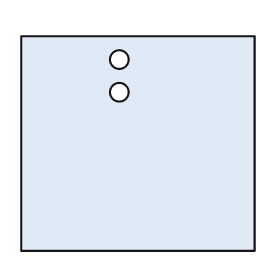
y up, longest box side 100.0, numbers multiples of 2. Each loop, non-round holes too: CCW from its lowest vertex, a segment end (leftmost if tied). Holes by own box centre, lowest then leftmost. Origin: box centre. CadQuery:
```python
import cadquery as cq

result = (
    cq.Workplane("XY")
    .moveTo(-50.0, -46.0)
    .lineTo(50.0, -46.0)
    .lineTo(50.0, 46.0)
    .lineTo(-50.0, 46.0)
    .close()
    .moveTo(-8.0, 22.0)
    .circle(4.0)
    .moveTo(-8.0, 36.0)
    .circle(4.0)
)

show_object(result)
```